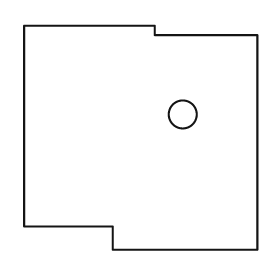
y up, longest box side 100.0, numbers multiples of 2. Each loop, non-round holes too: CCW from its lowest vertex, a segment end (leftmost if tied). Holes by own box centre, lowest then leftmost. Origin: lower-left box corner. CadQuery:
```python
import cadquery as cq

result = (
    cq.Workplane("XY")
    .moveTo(38.0, 0.0)
    .lineTo(100.0, 0.0)
    .lineTo(100.0, 92.0)
    .lineTo(56.0, 92.0)
    .lineTo(56.0, 96.0)
    .lineTo(0.0, 96.0)
    .lineTo(0.0, 10.0)
    .lineTo(38.0, 10.0)
    .close()
    .moveTo(68.0, 58.0)
    .circle(6.0)
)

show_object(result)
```